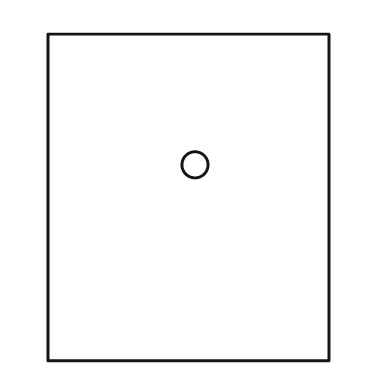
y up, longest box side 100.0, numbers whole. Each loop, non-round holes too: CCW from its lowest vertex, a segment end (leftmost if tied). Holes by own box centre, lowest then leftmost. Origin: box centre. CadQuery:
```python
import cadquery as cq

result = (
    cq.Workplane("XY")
    .moveTo(-43.0, -50.0)
    .lineTo(43.0, -50.0)
    .lineTo(43.0, 50.0)
    .lineTo(-43.0, 50.0)
    .close()
    .moveTo(2.0, 10.0)
    .circle(4.0)
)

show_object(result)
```